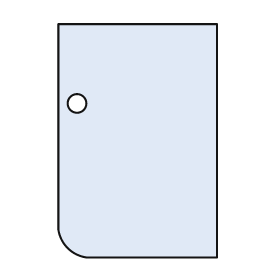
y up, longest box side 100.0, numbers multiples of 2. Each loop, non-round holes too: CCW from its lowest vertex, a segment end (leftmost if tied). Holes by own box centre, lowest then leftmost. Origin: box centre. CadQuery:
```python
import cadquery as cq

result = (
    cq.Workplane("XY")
    .moveTo(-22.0, -50.0)
    .lineTo(34.0, -50.0)
    .lineTo(34.0, 50.0)
    .lineTo(-34.0, 50.0)
    .lineTo(-34.0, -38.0)
    .threePointArc((-30.0, -46.0), (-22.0, -50.0))
    .close()
    .moveTo(-26.0, 16.0)
    .circle(4.0)
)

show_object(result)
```